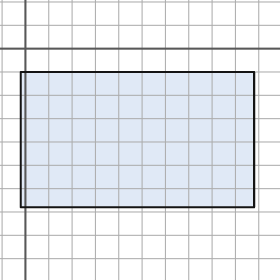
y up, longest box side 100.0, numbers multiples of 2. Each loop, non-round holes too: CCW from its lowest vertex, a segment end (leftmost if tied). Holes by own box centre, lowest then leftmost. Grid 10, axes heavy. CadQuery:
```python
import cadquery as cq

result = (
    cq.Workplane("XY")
    .moveTo(-2.0, -68.0)
    .lineTo(98.0, -68.0)
    .lineTo(98.0, -10.0)
    .lineTo(-2.0, -10.0)
    .close()
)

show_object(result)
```